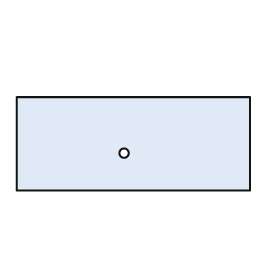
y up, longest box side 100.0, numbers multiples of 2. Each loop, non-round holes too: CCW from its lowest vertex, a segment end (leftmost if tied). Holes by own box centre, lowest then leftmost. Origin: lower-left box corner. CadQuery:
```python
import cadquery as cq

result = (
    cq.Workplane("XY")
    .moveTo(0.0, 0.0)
    .lineTo(100.0, 0.0)
    .lineTo(100.0, 40.0)
    .lineTo(0.0, 40.0)
    .close()
    .moveTo(46.0, 16.0)
    .circle(2.0)
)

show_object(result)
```